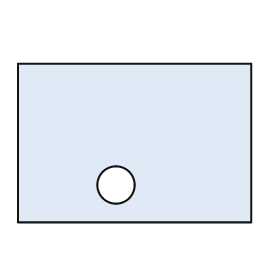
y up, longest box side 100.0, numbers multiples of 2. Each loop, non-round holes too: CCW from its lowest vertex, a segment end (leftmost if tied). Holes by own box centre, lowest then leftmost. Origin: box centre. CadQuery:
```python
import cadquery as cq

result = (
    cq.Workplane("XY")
    .moveTo(-50.0, -34.0)
    .lineTo(50.0, -34.0)
    .lineTo(50.0, 34.0)
    .lineTo(-50.0, 34.0)
    .close()
    .moveTo(-8.0, -18.0)
    .circle(8.0)
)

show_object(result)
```